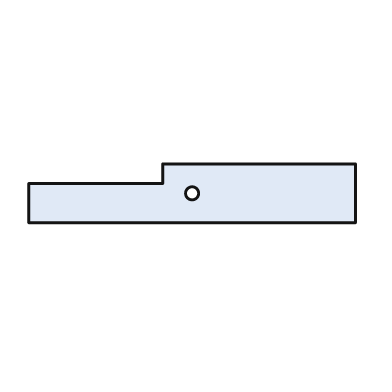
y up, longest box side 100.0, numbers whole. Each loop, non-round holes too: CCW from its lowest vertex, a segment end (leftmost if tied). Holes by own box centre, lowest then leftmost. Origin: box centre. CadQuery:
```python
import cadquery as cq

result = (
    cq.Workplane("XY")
    .moveTo(-50.0, -9.0)
    .lineTo(50.0, -9.0)
    .lineTo(50.0, 9.0)
    .lineTo(-9.0, 9.0)
    .lineTo(-9.0, 3.0)
    .lineTo(-50.0, 3.0)
    .close()
    .moveTo(0.0, 0.0)
    .circle(2.0)
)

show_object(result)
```